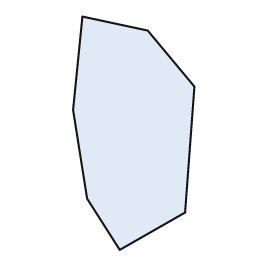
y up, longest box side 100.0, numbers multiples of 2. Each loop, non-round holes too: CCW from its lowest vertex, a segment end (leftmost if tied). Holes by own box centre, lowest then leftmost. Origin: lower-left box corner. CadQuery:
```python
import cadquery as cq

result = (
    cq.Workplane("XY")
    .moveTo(20.0, 0.0)
    .lineTo(48.0, 16.0)
    .lineTo(52.0, 70.0)
    .lineTo(32.0, 94.0)
    .lineTo(4.0, 100.0)
    .lineTo(0.0, 60.0)
    .lineTo(6.0, 22.0)
    .close()
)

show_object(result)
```